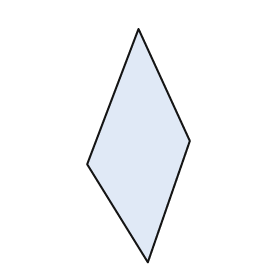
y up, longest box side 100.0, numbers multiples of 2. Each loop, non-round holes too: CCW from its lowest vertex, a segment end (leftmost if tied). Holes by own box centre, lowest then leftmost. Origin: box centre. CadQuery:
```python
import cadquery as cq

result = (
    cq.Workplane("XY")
    .moveTo(4.0, -50.0)
    .lineTo(22.0, 2.0)
    .lineTo(0.0, 50.0)
    .lineTo(-22.0, -8.0)
    .close()
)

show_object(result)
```